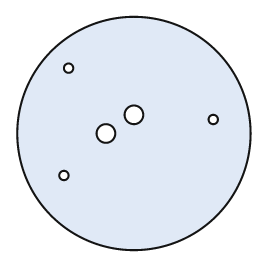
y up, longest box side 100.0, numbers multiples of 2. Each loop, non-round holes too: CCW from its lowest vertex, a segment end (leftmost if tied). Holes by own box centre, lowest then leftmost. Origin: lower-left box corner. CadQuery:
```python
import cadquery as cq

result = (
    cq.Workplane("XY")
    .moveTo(50.0, 50.0)
    .circle(50.0)
    .moveTo(20.0, 32.0)
    .circle(2.0)
    .moveTo(38.0, 50.0)
    .circle(4.0)
    .moveTo(84.0, 56.0)
    .circle(2.0)
    .moveTo(50.0, 58.0)
    .circle(4.0)
    .moveTo(22.0, 78.0)
    .circle(2.0)
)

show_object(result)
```